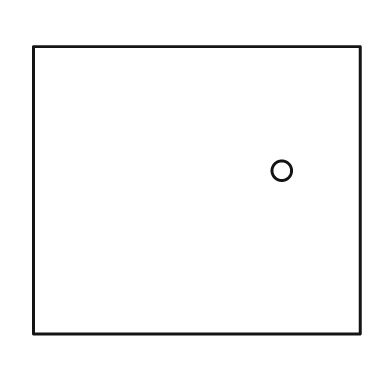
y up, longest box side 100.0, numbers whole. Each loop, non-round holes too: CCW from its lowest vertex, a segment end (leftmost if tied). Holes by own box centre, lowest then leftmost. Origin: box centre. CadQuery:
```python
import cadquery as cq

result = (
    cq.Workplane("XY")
    .moveTo(-50.0, -44.0)
    .lineTo(50.0, -44.0)
    .lineTo(50.0, 44.0)
    .lineTo(-50.0, 44.0)
    .close()
    .moveTo(26.0, 6.0)
    .circle(3.0)
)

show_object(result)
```